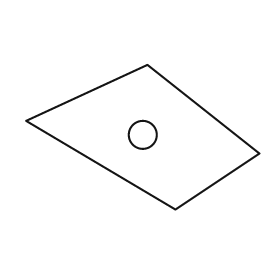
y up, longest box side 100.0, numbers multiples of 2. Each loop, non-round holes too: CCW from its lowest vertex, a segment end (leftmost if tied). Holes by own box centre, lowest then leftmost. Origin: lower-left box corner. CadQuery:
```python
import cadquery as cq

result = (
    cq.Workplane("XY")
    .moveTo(64.0, 0.0)
    .lineTo(100.0, 24.0)
    .lineTo(52.0, 62.0)
    .lineTo(0.0, 38.0)
    .close()
    .moveTo(50.0, 32.0)
    .circle(6.0)
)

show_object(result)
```